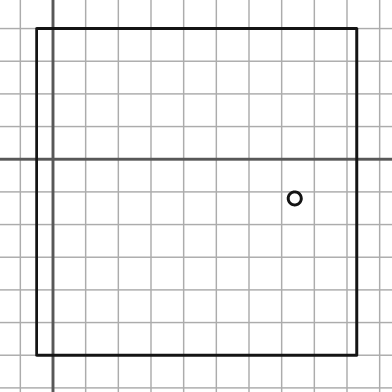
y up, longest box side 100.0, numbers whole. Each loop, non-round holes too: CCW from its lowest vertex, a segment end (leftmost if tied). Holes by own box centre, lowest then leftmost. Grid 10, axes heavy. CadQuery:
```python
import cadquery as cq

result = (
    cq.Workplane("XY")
    .moveTo(-5.0, -60.0)
    .lineTo(93.0, -60.0)
    .lineTo(93.0, 40.0)
    .lineTo(-5.0, 40.0)
    .close()
    .moveTo(74.0, -12.0)
    .circle(2.0)
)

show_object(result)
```